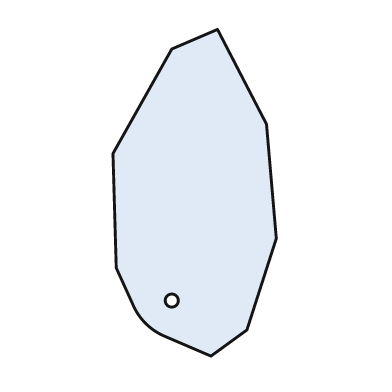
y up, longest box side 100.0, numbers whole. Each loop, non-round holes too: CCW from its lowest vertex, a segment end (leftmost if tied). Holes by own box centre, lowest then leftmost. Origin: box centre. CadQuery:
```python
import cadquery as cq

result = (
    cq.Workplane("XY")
    .moveTo(5.0, -50.0)
    .lineTo(16.0, -42.0)
    .lineTo(25.0, -14.0)
    .lineTo(22.0, 21.0)
    .lineTo(7.0, 50.0)
    .lineTo(-7.0, 44.0)
    .lineTo(-25.0, 12.0)
    .lineTo(-24.0, -23.0)
    .lineTo(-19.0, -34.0)
    .threePointArc((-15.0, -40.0), (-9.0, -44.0))
    .close()
    .moveTo(-7.0, -33.0)
    .circle(2.0)
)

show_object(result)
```